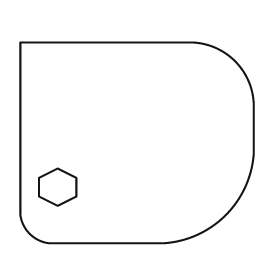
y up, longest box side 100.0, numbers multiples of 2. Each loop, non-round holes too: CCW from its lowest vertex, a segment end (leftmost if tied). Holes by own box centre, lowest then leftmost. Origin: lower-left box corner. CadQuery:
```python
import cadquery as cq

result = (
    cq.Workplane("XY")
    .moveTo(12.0, 0.0)
    .lineTo(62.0, 0.0)
    .threePointArc((88.0, 12.0), (100.0, 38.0))
    .lineTo(100.0, 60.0)
    .threePointArc((92.0, 78.0), (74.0, 86.0))
    .lineTo(0.0, 86.0)
    .lineTo(0.0, 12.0)
    .threePointArc((4.0, 4.0), (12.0, 0.0))
    .close()
    .moveTo(16.0, 16.0)
    .lineTo(24.0, 20.0)
    .lineTo(24.0, 28.0)
    .lineTo(16.0, 32.0)
    .lineTo(8.0, 28.0)
    .lineTo(8.0, 20.0)
    .close()
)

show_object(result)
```